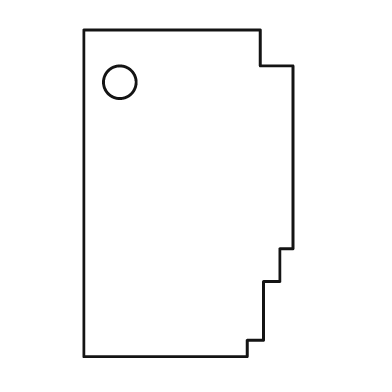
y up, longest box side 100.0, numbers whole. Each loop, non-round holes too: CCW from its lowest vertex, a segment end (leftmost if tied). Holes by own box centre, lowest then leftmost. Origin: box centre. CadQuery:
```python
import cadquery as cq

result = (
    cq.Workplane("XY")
    .moveTo(-32.0, -50.0)
    .lineTo(18.0, -50.0)
    .lineTo(18.0, -45.0)
    .lineTo(23.0, -45.0)
    .lineTo(23.0, -27.0)
    .lineTo(28.0, -27.0)
    .lineTo(28.0, -17.0)
    .lineTo(32.0, -17.0)
    .lineTo(32.0, 39.0)
    .lineTo(22.0, 39.0)
    .lineTo(22.0, 50.0)
    .lineTo(-32.0, 50.0)
    .close()
    .moveTo(-21.0, 34.0)
    .circle(5.0)
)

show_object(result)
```